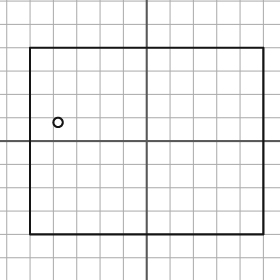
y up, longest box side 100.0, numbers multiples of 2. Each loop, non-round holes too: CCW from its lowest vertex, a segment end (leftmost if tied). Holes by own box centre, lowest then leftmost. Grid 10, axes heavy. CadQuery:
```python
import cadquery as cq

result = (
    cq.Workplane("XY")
    .moveTo(-50.0, -40.0)
    .lineTo(50.0, -40.0)
    .lineTo(50.0, 40.0)
    .lineTo(-50.0, 40.0)
    .close()
    .moveTo(-38.0, 8.0)
    .circle(2.0)
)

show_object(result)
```